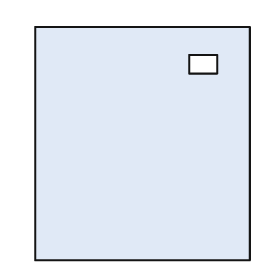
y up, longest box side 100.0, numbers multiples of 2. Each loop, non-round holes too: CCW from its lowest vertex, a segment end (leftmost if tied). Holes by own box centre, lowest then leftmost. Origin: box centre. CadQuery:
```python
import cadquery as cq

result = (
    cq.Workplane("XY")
    .moveTo(-46.0, -50.0)
    .lineTo(46.0, -50.0)
    .lineTo(46.0, 50.0)
    .lineTo(-46.0, 50.0)
    .close()
    .moveTo(20.0, 30.0)
    .lineTo(32.0, 30.0)
    .lineTo(32.0, 38.0)
    .lineTo(20.0, 38.0)
    .close()
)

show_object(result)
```